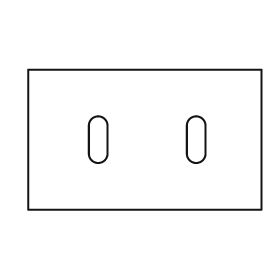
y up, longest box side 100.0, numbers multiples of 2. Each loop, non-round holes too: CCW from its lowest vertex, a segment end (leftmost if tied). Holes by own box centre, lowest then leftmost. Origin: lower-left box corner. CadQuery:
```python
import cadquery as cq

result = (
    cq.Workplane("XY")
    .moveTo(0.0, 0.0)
    .lineTo(100.0, 0.0)
    .lineTo(100.0, 60.0)
    .lineTo(0.0, 60.0)
    .close()
    .moveTo(26.0, 24.0)
    .threePointArc((30.0, 20.0), (34.0, 24.0))
    .lineTo(34.0, 36.0)
    .threePointArc((30.0, 40.0), (26.0, 36.0))
    .close()
    .moveTo(68.0, 24.0)
    .threePointArc((72.0, 20.0), (76.0, 24.0))
    .lineTo(76.0, 36.0)
    .threePointArc((72.0, 40.0), (68.0, 36.0))
    .close()
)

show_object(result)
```